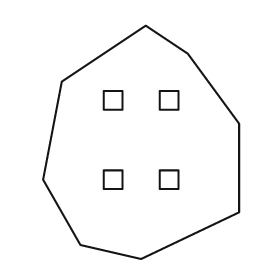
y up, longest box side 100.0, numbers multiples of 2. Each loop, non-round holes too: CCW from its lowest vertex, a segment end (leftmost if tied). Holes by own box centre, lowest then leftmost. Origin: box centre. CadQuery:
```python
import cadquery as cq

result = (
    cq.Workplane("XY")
    .moveTo(0.0, -50.0)
    .lineTo(42.0, -30.0)
    .lineTo(42.0, 8.0)
    .lineTo(20.0, 38.0)
    .lineTo(2.0, 50.0)
    .lineTo(-34.0, 26.0)
    .lineTo(-42.0, -16.0)
    .lineTo(-26.0, -44.0)
    .close()
    .moveTo(-16.0, -20.0)
    .lineTo(-8.0, -20.0)
    .lineTo(-8.0, -12.0)
    .lineTo(-16.0, -12.0)
    .close()
    .moveTo(8.0, -20.0)
    .lineTo(16.0, -20.0)
    .lineTo(16.0, -12.0)
    .lineTo(8.0, -12.0)
    .close()
    .moveTo(-16.0, 14.0)
    .lineTo(-8.0, 14.0)
    .lineTo(-8.0, 22.0)
    .lineTo(-16.0, 22.0)
    .close()
    .moveTo(8.0, 14.0)
    .lineTo(16.0, 14.0)
    .lineTo(16.0, 22.0)
    .lineTo(8.0, 22.0)
    .close()
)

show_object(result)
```